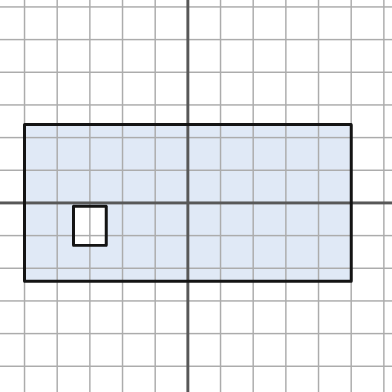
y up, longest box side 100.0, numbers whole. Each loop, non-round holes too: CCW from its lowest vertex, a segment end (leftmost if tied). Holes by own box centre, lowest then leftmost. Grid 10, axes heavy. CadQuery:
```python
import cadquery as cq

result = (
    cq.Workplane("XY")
    .moveTo(-50.0, -24.0)
    .lineTo(50.0, -24.0)
    .lineTo(50.0, 24.0)
    .lineTo(-50.0, 24.0)
    .close()
    .moveTo(-35.0, -13.0)
    .lineTo(-25.0, -13.0)
    .lineTo(-25.0, -1.0)
    .lineTo(-35.0, -1.0)
    .close()
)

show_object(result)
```